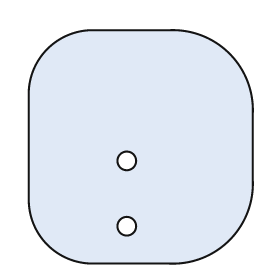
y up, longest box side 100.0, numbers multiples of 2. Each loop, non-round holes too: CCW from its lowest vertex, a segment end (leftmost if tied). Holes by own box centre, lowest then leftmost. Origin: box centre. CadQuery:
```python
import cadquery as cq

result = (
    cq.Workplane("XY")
    .moveTo(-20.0, -50.0)
    .lineTo(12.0, -50.0)
    .threePointArc((38.0, -40.0), (48.0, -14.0))
    .lineTo(48.0, 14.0)
    .threePointArc((38.0, 40.0), (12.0, 50.0))
    .lineTo(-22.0, 50.0)
    .threePointArc((-40.0, 42.0), (-48.0, 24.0))
    .lineTo(-48.0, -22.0)
    .threePointArc((-40.0, -42.0), (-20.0, -50.0))
    .close()
    .moveTo(-6.0, -34.0)
    .circle(4.0)
    .moveTo(-6.0, -6.0)
    .circle(4.0)
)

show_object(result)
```